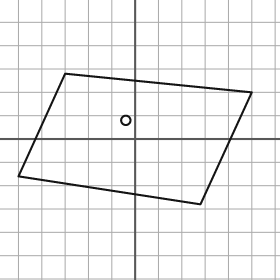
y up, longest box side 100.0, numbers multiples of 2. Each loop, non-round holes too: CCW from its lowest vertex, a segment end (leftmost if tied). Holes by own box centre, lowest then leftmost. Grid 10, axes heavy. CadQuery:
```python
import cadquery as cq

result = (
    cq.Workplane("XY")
    .moveTo(28.0, -28.0)
    .lineTo(50.0, 20.0)
    .lineTo(-30.0, 28.0)
    .lineTo(-50.0, -16.0)
    .close()
    .moveTo(-4.0, 8.0)
    .circle(2.0)
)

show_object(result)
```